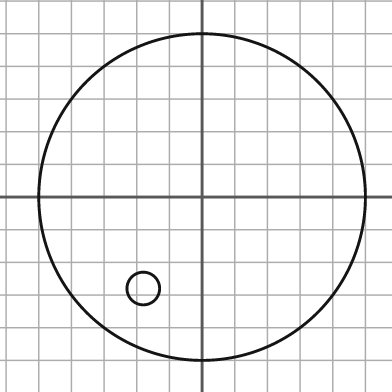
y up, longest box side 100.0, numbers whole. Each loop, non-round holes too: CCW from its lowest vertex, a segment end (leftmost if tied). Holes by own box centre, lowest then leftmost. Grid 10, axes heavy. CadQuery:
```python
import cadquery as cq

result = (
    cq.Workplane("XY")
    .moveTo(0.0, 0.0)
    .circle(50.0)
    .moveTo(-18.0, -28.0)
    .circle(5.0)
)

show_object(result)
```